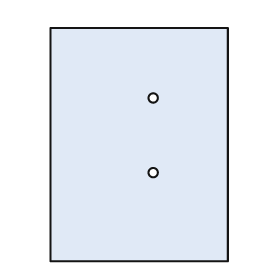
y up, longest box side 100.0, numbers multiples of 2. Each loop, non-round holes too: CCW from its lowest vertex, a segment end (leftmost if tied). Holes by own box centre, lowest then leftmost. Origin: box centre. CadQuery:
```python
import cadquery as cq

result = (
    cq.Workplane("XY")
    .moveTo(-38.0, -50.0)
    .lineTo(38.0, -50.0)
    .lineTo(38.0, 50.0)
    .lineTo(-38.0, 50.0)
    .close()
    .moveTo(6.0, -12.0)
    .circle(2.0)
    .moveTo(6.0, 20.0)
    .circle(2.0)
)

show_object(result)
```